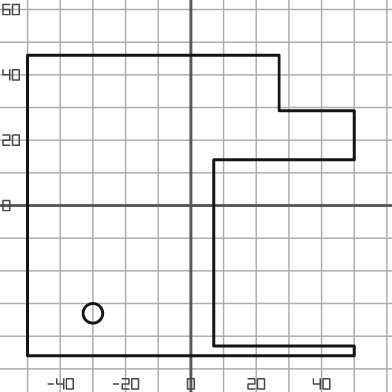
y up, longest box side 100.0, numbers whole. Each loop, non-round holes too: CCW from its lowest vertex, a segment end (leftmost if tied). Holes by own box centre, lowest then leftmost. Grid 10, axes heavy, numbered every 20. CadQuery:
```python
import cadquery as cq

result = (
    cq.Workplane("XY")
    .moveTo(-50.0, -46.0)
    .lineTo(50.0, -46.0)
    .lineTo(50.0, -43.0)
    .lineTo(7.0, -43.0)
    .lineTo(7.0, 14.0)
    .lineTo(50.0, 14.0)
    .lineTo(50.0, 29.0)
    .lineTo(27.0, 29.0)
    .lineTo(27.0, 46.0)
    .lineTo(-50.0, 46.0)
    .close()
    .moveTo(-30.0, -33.0)
    .circle(3.0)
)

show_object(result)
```